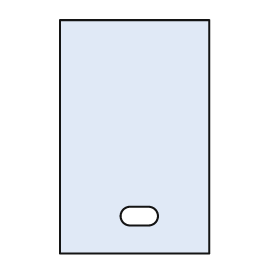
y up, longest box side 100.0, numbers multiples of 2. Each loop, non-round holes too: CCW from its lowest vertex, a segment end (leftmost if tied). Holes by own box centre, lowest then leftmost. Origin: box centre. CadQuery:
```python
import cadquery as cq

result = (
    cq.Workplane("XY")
    .moveTo(-32.0, -50.0)
    .lineTo(32.0, -50.0)
    .lineTo(32.0, 50.0)
    .lineTo(-32.0, 50.0)
    .close()
    .moveTo(-2.0, -38.0)
    .lineTo(6.0, -38.0)
    .threePointArc((10.0, -34.0), (6.0, -30.0))
    .lineTo(-2.0, -30.0)
    .threePointArc((-6.0, -34.0), (-2.0, -38.0))
    .close()
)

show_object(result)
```